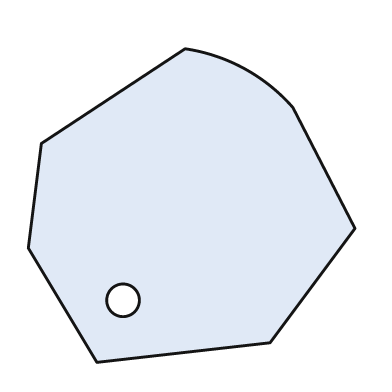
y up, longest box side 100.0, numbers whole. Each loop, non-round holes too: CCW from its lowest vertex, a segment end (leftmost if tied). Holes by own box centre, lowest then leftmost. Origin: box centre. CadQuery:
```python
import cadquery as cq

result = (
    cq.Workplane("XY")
    .moveTo(-29.0, -48.0)
    .lineTo(24.0, -42.0)
    .lineTo(50.0, -7.0)
    .lineTo(31.0, 30.0)
    .threePointArc((16.0, 42.0), (-2.0, 48.0))
    .lineTo(-46.0, 19.0)
    .lineTo(-50.0, -13.0)
    .close()
    .moveTo(-21.0, -29.0)
    .circle(5.0)
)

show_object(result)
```